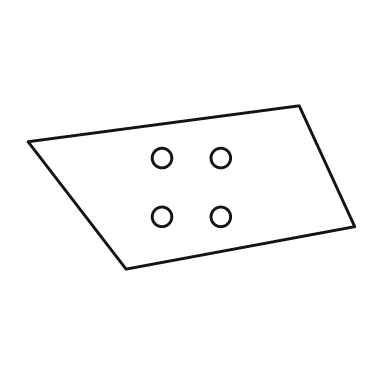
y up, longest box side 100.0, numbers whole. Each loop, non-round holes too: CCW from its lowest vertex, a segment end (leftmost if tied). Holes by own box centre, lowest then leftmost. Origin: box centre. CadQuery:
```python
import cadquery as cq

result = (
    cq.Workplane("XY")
    .moveTo(-20.0, -25.0)
    .lineTo(50.0, -12.0)
    .lineTo(33.0, 25.0)
    .lineTo(-50.0, 14.0)
    .close()
    .moveTo(-9.0, -9.0)
    .circle(3.0)
    .moveTo(9.0, -9.0)
    .circle(3.0)
    .moveTo(-9.0, 9.0)
    .circle(3.0)
    .moveTo(9.0, 9.0)
    .circle(3.0)
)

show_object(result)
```